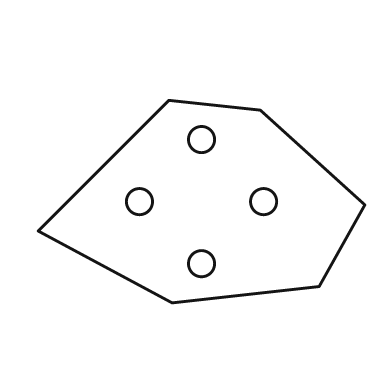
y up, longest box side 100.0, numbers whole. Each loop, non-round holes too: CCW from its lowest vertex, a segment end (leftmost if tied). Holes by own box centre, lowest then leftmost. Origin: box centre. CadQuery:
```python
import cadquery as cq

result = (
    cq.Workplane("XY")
    .moveTo(-9.0, -31.0)
    .lineTo(36.0, -26.0)
    .lineTo(50.0, -1.0)
    .lineTo(18.0, 28.0)
    .lineTo(-10.0, 31.0)
    .lineTo(-50.0, -9.0)
    .close()
    .moveTo(0.0, -19.0)
    .circle(4.0)
    .moveTo(-19.0, 0.0)
    .circle(4.0)
    .moveTo(19.0, 0.0)
    .circle(4.0)
    .moveTo(0.0, 19.0)
    .circle(4.0)
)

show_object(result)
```